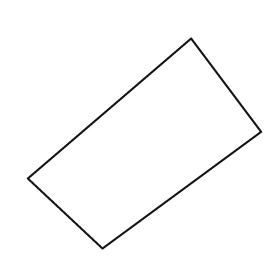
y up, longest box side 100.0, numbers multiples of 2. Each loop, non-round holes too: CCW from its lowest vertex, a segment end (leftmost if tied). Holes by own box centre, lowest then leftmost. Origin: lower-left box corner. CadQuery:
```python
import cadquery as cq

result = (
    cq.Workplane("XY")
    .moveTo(32.0, 0.0)
    .lineTo(100.0, 50.0)
    .lineTo(70.0, 90.0)
    .lineTo(0.0, 30.0)
    .close()
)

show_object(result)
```